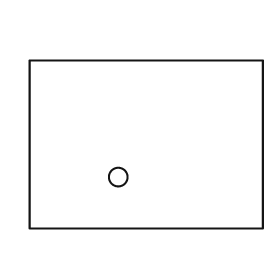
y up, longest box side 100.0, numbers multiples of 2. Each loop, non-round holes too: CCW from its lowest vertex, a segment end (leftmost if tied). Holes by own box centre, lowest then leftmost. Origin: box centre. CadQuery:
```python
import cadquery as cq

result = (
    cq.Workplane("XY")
    .moveTo(-50.0, -36.0)
    .lineTo(50.0, -36.0)
    .lineTo(50.0, 36.0)
    .lineTo(-50.0, 36.0)
    .close()
    .moveTo(-12.0, -14.0)
    .circle(4.0)
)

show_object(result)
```